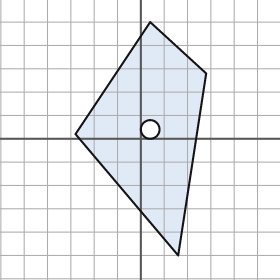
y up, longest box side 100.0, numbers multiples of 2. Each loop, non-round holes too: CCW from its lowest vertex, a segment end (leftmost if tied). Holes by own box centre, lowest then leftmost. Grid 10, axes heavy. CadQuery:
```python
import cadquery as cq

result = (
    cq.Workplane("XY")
    .moveTo(16.0, -50.0)
    .lineTo(28.0, 28.0)
    .lineTo(4.0, 50.0)
    .lineTo(-28.0, 2.0)
    .close()
    .moveTo(4.0, 4.0)
    .circle(4.0)
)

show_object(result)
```